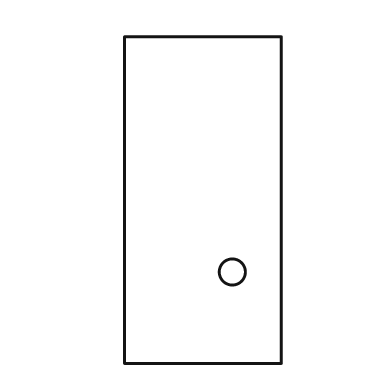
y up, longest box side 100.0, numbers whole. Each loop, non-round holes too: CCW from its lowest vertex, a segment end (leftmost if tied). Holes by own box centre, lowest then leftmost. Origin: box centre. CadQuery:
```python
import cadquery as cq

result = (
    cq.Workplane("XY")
    .moveTo(-24.0, -50.0)
    .lineTo(24.0, -50.0)
    .lineTo(24.0, 50.0)
    .lineTo(-24.0, 50.0)
    .close()
    .moveTo(9.0, -22.0)
    .circle(4.0)
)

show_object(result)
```